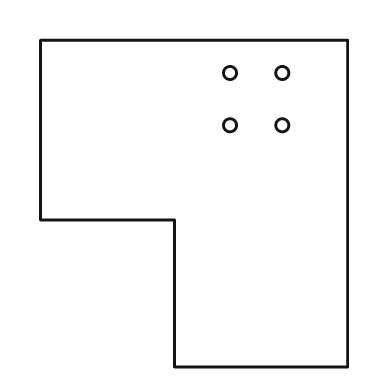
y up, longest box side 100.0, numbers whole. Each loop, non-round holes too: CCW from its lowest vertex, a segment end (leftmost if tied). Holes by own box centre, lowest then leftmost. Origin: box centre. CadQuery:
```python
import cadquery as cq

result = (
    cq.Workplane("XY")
    .moveTo(-6.0, -50.0)
    .lineTo(47.0, -50.0)
    .lineTo(47.0, 50.0)
    .lineTo(-47.0, 50.0)
    .lineTo(-47.0, -5.0)
    .lineTo(-6.0, -5.0)
    .close()
    .moveTo(11.0, 24.0)
    .circle(2.0)
    .moveTo(27.0, 24.0)
    .circle(2.0)
    .moveTo(11.0, 40.0)
    .circle(2.0)
    .moveTo(27.0, 40.0)
    .circle(2.0)
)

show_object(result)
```